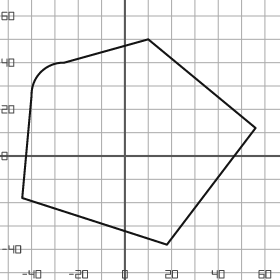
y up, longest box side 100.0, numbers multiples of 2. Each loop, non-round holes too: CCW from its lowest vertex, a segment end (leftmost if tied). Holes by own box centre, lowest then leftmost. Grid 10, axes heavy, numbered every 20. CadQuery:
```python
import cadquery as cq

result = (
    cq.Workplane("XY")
    .moveTo(18.0, -38.0)
    .lineTo(56.0, 12.0)
    .lineTo(10.0, 50.0)
    .lineTo(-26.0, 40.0)
    .threePointArc((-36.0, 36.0), (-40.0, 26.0))
    .lineTo(-44.0, -18.0)
    .close()
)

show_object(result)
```